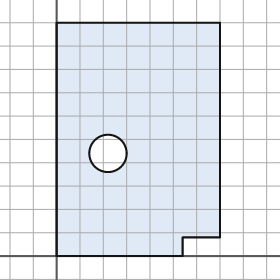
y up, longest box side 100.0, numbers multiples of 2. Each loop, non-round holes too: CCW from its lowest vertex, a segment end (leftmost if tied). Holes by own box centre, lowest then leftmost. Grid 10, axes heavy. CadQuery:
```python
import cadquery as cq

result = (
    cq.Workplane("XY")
    .moveTo(0.0, 0.0)
    .lineTo(54.0, 0.0)
    .lineTo(54.0, 8.0)
    .lineTo(70.0, 8.0)
    .lineTo(70.0, 100.0)
    .lineTo(0.0, 100.0)
    .close()
    .moveTo(22.0, 44.0)
    .circle(8.0)
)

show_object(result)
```